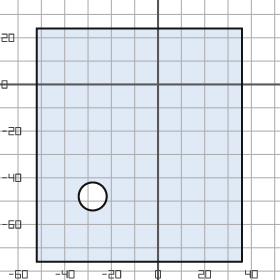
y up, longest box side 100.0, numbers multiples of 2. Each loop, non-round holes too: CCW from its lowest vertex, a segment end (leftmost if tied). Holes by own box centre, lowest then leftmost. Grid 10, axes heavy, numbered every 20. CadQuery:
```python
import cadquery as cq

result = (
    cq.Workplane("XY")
    .moveTo(-52.0, -76.0)
    .lineTo(36.0, -76.0)
    .lineTo(36.0, 24.0)
    .lineTo(-52.0, 24.0)
    .close()
    .moveTo(-28.0, -48.0)
    .circle(6.0)
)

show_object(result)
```